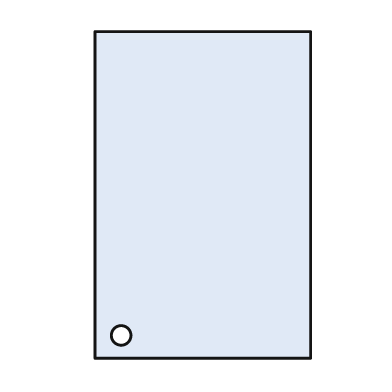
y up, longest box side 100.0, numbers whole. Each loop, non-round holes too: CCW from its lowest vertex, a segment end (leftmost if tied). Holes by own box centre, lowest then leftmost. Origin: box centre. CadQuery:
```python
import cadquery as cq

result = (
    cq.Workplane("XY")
    .moveTo(-33.0, -50.0)
    .lineTo(33.0, -50.0)
    .lineTo(33.0, 50.0)
    .lineTo(-33.0, 50.0)
    .close()
    .moveTo(-25.0, -43.0)
    .circle(3.0)
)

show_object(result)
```